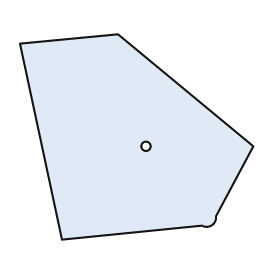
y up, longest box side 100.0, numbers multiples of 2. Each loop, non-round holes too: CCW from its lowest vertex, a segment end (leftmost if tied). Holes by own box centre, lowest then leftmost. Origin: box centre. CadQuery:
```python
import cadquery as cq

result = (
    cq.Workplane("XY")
    .moveTo(-32.0, -44.0)
    .lineTo(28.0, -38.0)
    .threePointArc((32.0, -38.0), (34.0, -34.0))
    .lineTo(50.0, -4.0)
    .lineTo(-8.0, 44.0)
    .lineTo(-50.0, 40.0)
    .close()
    .moveTo(4.0, -4.0)
    .circle(2.0)
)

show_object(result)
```